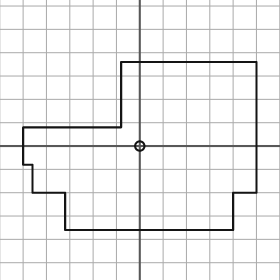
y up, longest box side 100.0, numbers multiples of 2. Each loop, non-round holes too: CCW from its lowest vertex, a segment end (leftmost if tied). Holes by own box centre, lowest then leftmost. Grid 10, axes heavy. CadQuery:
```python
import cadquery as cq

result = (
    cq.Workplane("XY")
    .moveTo(-32.0, -36.0)
    .lineTo(40.0, -36.0)
    .lineTo(40.0, -20.0)
    .lineTo(50.0, -20.0)
    .lineTo(50.0, 36.0)
    .lineTo(-8.0, 36.0)
    .lineTo(-8.0, 8.0)
    .lineTo(-50.0, 8.0)
    .lineTo(-50.0, -8.0)
    .lineTo(-46.0, -8.0)
    .lineTo(-46.0, -20.0)
    .lineTo(-32.0, -20.0)
    .close()
    .moveTo(0.0, 0.0)
    .circle(2.0)
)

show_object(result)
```